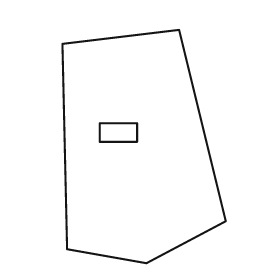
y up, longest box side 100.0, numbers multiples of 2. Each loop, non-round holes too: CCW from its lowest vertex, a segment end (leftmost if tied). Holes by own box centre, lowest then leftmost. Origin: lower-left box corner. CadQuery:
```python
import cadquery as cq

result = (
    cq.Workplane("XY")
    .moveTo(36.0, 0.0)
    .lineTo(70.0, 18.0)
    .lineTo(50.0, 100.0)
    .lineTo(0.0, 94.0)
    .lineTo(2.0, 6.0)
    .close()
    .moveTo(16.0, 52.0)
    .lineTo(32.0, 52.0)
    .lineTo(32.0, 60.0)
    .lineTo(16.0, 60.0)
    .close()
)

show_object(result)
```